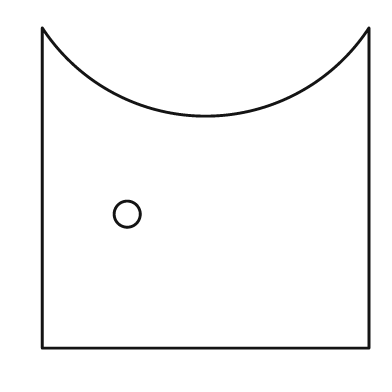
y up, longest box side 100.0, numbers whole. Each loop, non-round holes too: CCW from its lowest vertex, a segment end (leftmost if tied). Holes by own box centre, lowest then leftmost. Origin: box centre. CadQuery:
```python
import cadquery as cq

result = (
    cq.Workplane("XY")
    .moveTo(-50.0, -49.0)
    .lineTo(50.0, -49.0)
    .lineTo(50.0, 49.0)
    .threePointArc((0.0, 22.0), (-50.0, 49.0))
    .close()
    .moveTo(-24.0, -8.0)
    .circle(4.0)
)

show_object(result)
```